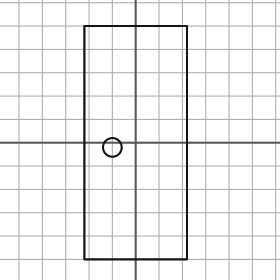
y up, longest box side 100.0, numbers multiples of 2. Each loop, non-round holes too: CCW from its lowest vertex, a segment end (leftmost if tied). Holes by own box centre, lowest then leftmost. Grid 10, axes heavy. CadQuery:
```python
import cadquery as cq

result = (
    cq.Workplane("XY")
    .moveTo(-22.0, -50.0)
    .lineTo(22.0, -50.0)
    .lineTo(22.0, 50.0)
    .lineTo(-22.0, 50.0)
    .close()
    .moveTo(-10.0, -2.0)
    .circle(4.0)
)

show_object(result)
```